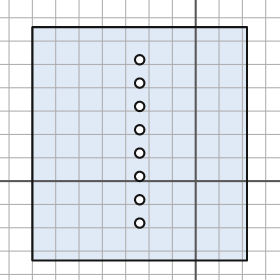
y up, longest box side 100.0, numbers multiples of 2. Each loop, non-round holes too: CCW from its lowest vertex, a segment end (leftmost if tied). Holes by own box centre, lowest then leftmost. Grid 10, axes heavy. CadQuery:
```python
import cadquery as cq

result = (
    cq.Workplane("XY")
    .moveTo(-70.0, -34.0)
    .lineTo(22.0, -34.0)
    .lineTo(22.0, 66.0)
    .lineTo(-70.0, 66.0)
    .close()
    .moveTo(-24.0, -18.0)
    .circle(2.0)
    .moveTo(-24.0, -8.0)
    .circle(2.0)
    .moveTo(-24.0, 2.0)
    .circle(2.0)
    .moveTo(-24.0, 12.0)
    .circle(2.0)
    .moveTo(-24.0, 22.0)
    .circle(2.0)
    .moveTo(-24.0, 32.0)
    .circle(2.0)
    .moveTo(-24.0, 42.0)
    .circle(2.0)
    .moveTo(-24.0, 52.0)
    .circle(2.0)
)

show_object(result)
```